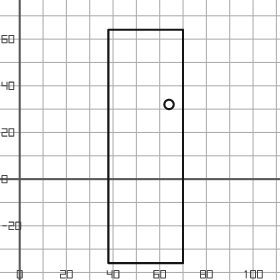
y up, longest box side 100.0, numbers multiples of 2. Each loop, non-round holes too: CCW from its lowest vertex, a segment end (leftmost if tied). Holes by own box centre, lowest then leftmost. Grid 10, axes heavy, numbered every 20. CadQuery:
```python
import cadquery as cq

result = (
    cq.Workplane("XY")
    .moveTo(38.0, -36.0)
    .lineTo(70.0, -36.0)
    .lineTo(70.0, 64.0)
    .lineTo(38.0, 64.0)
    .close()
    .moveTo(64.0, 32.0)
    .circle(2.0)
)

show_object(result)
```